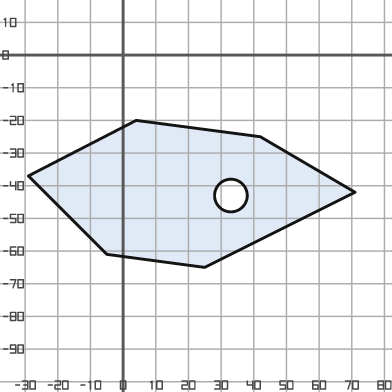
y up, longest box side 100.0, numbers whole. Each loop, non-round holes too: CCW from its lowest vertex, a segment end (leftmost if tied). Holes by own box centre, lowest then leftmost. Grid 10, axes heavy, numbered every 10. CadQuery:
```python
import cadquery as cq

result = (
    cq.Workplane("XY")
    .moveTo(25.0, -65.0)
    .lineTo(71.0, -42.0)
    .lineTo(42.0, -25.0)
    .lineTo(4.0, -20.0)
    .lineTo(-29.0, -37.0)
    .lineTo(-5.0, -61.0)
    .close()
    .moveTo(33.0, -43.0)
    .circle(5.0)
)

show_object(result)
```